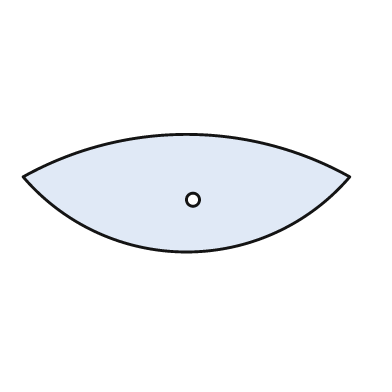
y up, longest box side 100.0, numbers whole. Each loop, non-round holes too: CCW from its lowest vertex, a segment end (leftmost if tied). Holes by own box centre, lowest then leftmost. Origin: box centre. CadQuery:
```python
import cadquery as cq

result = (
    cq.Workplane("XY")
    .moveTo(-50.0, 5.0)
    .threePointArc((0.0, -18.0), (50.0, 5.0))
    .threePointArc((0.0, 18.0), (-50.0, 5.0))
    .close()
    .moveTo(2.0, -2.0)
    .circle(2.0)
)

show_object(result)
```